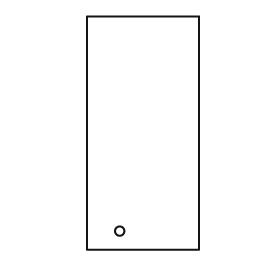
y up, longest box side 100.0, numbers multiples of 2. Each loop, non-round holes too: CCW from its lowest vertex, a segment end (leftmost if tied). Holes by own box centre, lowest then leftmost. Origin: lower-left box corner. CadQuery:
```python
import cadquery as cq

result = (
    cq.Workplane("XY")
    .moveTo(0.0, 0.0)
    .lineTo(48.0, 0.0)
    .lineTo(48.0, 100.0)
    .lineTo(0.0, 100.0)
    .close()
    .moveTo(14.0, 8.0)
    .circle(2.0)
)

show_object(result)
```